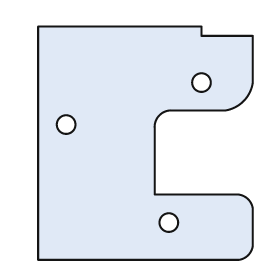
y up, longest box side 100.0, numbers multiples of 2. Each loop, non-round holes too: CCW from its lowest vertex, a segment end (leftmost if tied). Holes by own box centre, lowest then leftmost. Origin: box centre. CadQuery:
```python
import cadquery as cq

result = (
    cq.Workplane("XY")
    .moveTo(-46.0, -50.0)
    .lineTo(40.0, -50.0)
    .threePointArc((44.0, -48.0), (46.0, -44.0))
    .lineTo(46.0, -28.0)
    .threePointArc((44.0, -24.0), (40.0, -22.0))
    .lineTo(4.0, -22.0)
    .lineTo(4.0, 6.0)
    .threePointArc((6.0, 12.0), (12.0, 14.0))
    .lineTo(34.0, 14.0)
    .threePointArc((42.0, 18.0), (46.0, 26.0))
    .lineTo(46.0, 46.0)
    .lineTo(24.0, 46.0)
    .lineTo(24.0, 50.0)
    .lineTo(-46.0, 50.0)
    .close()
    .moveTo(10.0, -34.0)
    .circle(4.0)
    .moveTo(-34.0, 8.0)
    .circle(4.0)
    .moveTo(24.0, 26.0)
    .circle(4.0)
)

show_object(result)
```